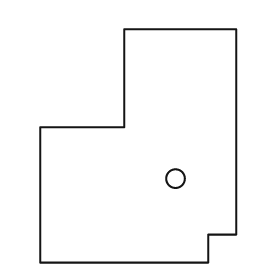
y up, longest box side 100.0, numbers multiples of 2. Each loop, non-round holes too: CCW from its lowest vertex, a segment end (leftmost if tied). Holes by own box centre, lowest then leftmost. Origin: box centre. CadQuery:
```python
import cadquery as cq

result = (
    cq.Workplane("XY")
    .moveTo(-42.0, -50.0)
    .lineTo(30.0, -50.0)
    .lineTo(30.0, -38.0)
    .lineTo(42.0, -38.0)
    .lineTo(42.0, 50.0)
    .lineTo(-6.0, 50.0)
    .lineTo(-6.0, 8.0)
    .lineTo(-42.0, 8.0)
    .close()
    .moveTo(16.0, -14.0)
    .circle(4.0)
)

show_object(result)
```